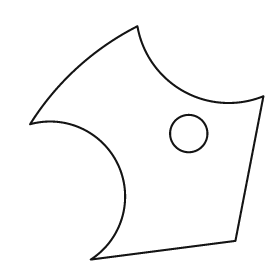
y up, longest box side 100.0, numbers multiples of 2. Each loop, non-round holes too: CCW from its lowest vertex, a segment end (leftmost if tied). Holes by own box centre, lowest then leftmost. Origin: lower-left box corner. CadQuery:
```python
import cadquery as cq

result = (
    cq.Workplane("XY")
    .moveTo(26.0, 0.0)
    .lineTo(88.0, 8.0)
    .lineTo(100.0, 70.0)
    .threePointArc((66.0, 72.0), (46.0, 100.0))
    .threePointArc((20.0, 82.0), (0.0, 58.0))
    .threePointArc((38.0, 40.0), (26.0, 0.0))
    .close()
    .moveTo(68.0, 54.0)
    .circle(8.0)
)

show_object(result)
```